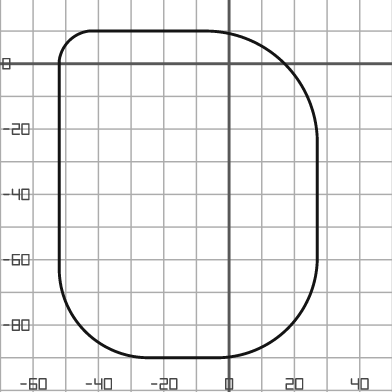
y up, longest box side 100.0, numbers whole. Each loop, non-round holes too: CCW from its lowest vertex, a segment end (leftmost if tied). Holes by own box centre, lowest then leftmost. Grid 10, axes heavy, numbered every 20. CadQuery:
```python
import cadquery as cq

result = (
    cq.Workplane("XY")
    .moveTo(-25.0, -90.0)
    .lineTo(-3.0, -90.0)
    .threePointArc((18.0, -81.0), (27.0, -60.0))
    .lineTo(27.0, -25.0)
    .threePointArc((17.0, 0.0), (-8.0, 10.0))
    .lineTo(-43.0, 10.0)
    .threePointArc((-49.0, 7.0), (-52.0, 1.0))
    .lineTo(-52.0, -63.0)
    .threePointArc((-44.0, -82.0), (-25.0, -90.0))
    .close()
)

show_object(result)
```